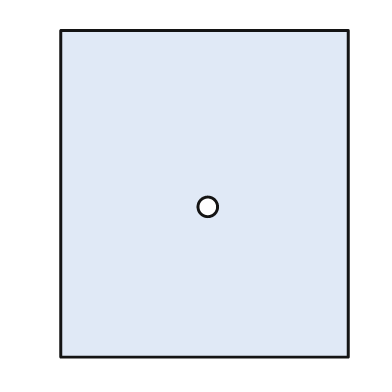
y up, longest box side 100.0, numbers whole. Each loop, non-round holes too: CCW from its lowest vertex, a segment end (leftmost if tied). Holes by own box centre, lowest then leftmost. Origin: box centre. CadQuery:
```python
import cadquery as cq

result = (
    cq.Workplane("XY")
    .moveTo(-44.0, -50.0)
    .lineTo(44.0, -50.0)
    .lineTo(44.0, 50.0)
    .lineTo(-44.0, 50.0)
    .close()
    .moveTo(1.0, -4.0)
    .circle(3.0)
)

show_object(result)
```